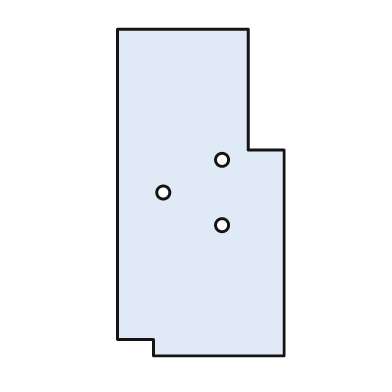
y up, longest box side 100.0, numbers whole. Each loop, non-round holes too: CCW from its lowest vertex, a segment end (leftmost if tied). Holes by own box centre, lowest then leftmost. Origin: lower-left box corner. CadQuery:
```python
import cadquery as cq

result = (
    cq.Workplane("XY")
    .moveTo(11.0, 0.0)
    .lineTo(51.0, 0.0)
    .lineTo(51.0, 63.0)
    .lineTo(40.0, 63.0)
    .lineTo(40.0, 100.0)
    .lineTo(0.0, 100.0)
    .lineTo(0.0, 5.0)
    .lineTo(11.0, 5.0)
    .close()
    .moveTo(32.0, 40.0)
    .circle(2.0)
    .moveTo(14.0, 50.0)
    .circle(2.0)
    .moveTo(32.0, 60.0)
    .circle(2.0)
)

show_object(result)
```